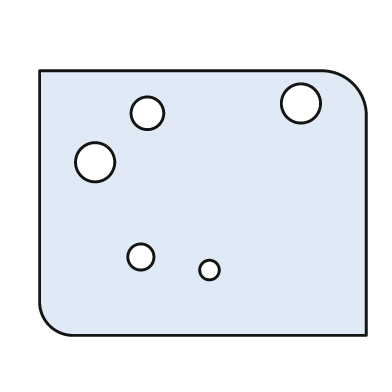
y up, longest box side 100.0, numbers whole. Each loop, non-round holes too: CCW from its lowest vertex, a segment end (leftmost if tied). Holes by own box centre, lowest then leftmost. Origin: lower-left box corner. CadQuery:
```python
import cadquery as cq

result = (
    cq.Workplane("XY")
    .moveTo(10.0, 0.0)
    .lineTo(100.0, 0.0)
    .lineTo(100.0, 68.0)
    .threePointArc((96.0, 77.0), (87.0, 81.0))
    .lineTo(0.0, 81.0)
    .lineTo(0.0, 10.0)
    .threePointArc((3.0, 3.0), (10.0, 0.0))
    .close()
    .moveTo(52.0, 20.0)
    .circle(3.0)
    .moveTo(31.0, 24.0)
    .circle(4.0)
    .moveTo(17.0, 53.0)
    .circle(6.0)
    .moveTo(33.0, 68.0)
    .circle(5.0)
    .moveTo(80.0, 71.0)
    .circle(6.0)
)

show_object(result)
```